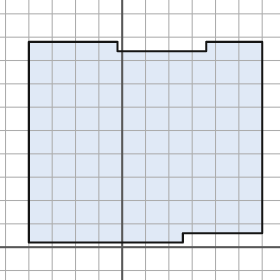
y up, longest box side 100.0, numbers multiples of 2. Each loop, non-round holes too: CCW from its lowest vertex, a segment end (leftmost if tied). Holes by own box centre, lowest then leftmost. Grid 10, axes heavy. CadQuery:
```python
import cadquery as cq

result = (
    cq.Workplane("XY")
    .moveTo(-40.0, 2.0)
    .lineTo(26.0, 2.0)
    .lineTo(26.0, 6.0)
    .lineTo(60.0, 6.0)
    .lineTo(60.0, 88.0)
    .lineTo(36.0, 88.0)
    .lineTo(36.0, 84.0)
    .lineTo(-2.0, 84.0)
    .lineTo(-2.0, 88.0)
    .lineTo(-40.0, 88.0)
    .close()
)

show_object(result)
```